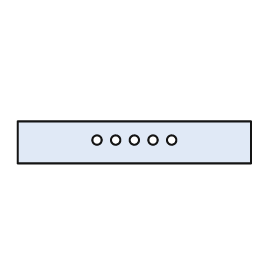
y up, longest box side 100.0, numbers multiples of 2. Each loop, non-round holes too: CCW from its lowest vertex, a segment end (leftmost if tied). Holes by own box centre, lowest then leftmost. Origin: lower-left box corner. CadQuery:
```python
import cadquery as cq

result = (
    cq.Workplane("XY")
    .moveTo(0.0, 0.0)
    .lineTo(100.0, 0.0)
    .lineTo(100.0, 18.0)
    .lineTo(0.0, 18.0)
    .close()
    .moveTo(34.0, 10.0)
    .circle(2.0)
    .moveTo(42.0, 10.0)
    .circle(2.0)
    .moveTo(50.0, 10.0)
    .circle(2.0)
    .moveTo(58.0, 10.0)
    .circle(2.0)
    .moveTo(66.0, 10.0)
    .circle(2.0)
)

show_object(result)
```